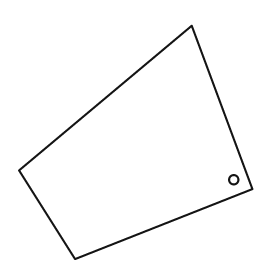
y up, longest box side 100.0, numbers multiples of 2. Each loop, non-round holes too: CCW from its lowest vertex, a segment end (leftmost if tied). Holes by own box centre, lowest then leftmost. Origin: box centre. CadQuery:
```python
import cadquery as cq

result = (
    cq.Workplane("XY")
    .moveTo(-26.0, -50.0)
    .lineTo(50.0, -20.0)
    .lineTo(24.0, 50.0)
    .lineTo(-50.0, -12.0)
    .close()
    .moveTo(42.0, -16.0)
    .circle(2.0)
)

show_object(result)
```